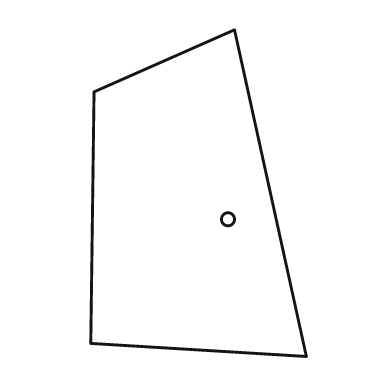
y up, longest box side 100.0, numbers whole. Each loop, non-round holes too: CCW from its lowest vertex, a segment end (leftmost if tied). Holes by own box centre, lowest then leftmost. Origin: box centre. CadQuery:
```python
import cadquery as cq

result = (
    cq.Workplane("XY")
    .moveTo(33.0, -50.0)
    .lineTo(11.0, 50.0)
    .lineTo(-32.0, 31.0)
    .lineTo(-33.0, -46.0)
    .close()
    .moveTo(9.0, -8.0)
    .circle(2.0)
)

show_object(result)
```